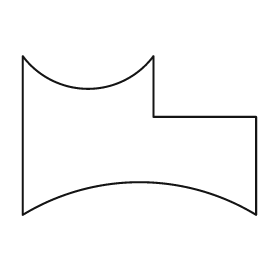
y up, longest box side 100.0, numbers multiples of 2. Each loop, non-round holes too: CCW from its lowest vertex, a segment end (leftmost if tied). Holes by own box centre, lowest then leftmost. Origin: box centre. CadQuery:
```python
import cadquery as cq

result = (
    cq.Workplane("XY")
    .moveTo(-50.0, -34.0)
    .threePointArc((0.0, -20.0), (50.0, -34.0))
    .lineTo(50.0, 8.0)
    .lineTo(6.0, 8.0)
    .lineTo(6.0, 34.0)
    .threePointArc((-22.0, 20.0), (-50.0, 34.0))
    .close()
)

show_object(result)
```